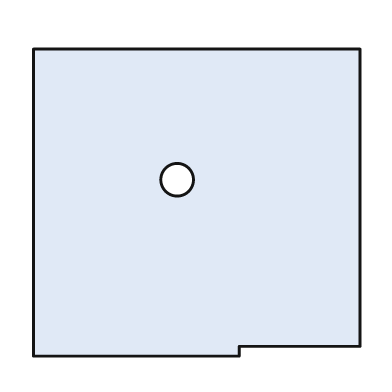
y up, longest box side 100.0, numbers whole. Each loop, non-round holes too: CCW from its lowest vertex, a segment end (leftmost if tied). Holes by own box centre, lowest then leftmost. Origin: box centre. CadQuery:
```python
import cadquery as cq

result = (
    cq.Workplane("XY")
    .moveTo(-50.0, -47.0)
    .lineTo(13.0, -47.0)
    .lineTo(13.0, -44.0)
    .lineTo(50.0, -44.0)
    .lineTo(50.0, 47.0)
    .lineTo(-50.0, 47.0)
    .close()
    .moveTo(-6.0, 7.0)
    .circle(5.0)
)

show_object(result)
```